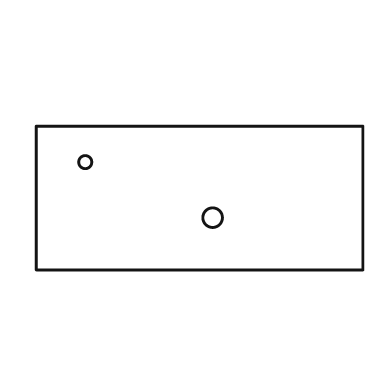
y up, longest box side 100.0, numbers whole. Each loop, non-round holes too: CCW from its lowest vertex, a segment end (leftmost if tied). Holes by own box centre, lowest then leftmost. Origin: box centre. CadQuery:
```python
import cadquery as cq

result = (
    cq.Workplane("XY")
    .moveTo(-50.0, -22.0)
    .lineTo(50.0, -22.0)
    .lineTo(50.0, 22.0)
    .lineTo(-50.0, 22.0)
    .close()
    .moveTo(4.0, -6.0)
    .circle(3.0)
    .moveTo(-35.0, 11.0)
    .circle(2.0)
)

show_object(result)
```